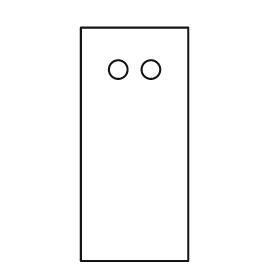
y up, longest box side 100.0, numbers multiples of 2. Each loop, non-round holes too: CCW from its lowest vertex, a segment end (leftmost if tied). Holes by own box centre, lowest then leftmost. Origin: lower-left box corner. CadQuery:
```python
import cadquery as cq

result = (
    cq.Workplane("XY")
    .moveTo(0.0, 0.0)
    .lineTo(46.0, 0.0)
    .lineTo(46.0, 100.0)
    .lineTo(0.0, 100.0)
    .close()
    .moveTo(16.0, 82.0)
    .circle(4.0)
    .moveTo(30.0, 82.0)
    .circle(4.0)
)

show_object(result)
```